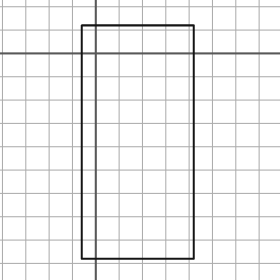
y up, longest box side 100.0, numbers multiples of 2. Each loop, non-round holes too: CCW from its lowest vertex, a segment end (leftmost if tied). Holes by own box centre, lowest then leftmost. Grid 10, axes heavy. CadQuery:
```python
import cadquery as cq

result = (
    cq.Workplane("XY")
    .moveTo(-6.0, -88.0)
    .lineTo(42.0, -88.0)
    .lineTo(42.0, 12.0)
    .lineTo(-6.0, 12.0)
    .close()
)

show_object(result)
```